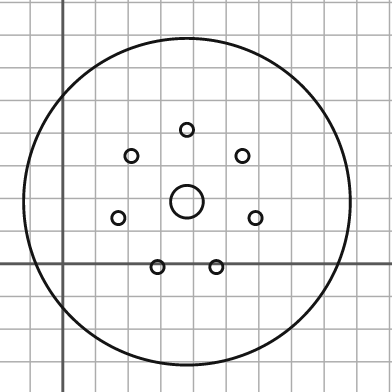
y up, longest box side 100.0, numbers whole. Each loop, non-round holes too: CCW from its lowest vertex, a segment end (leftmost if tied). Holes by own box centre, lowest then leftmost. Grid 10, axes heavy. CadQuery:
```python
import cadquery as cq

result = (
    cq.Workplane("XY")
    .moveTo(38.0, 19.0)
    .circle(50.0)
    .moveTo(29.0, -1.0)
    .circle(2.0)
    .moveTo(47.0, -1.0)
    .circle(2.0)
    .moveTo(17.0, 14.0)
    .circle(2.0)
    .moveTo(59.0, 14.0)
    .circle(2.0)
    .moveTo(38.0, 19.0)
    .circle(5.0)
    .moveTo(21.0, 33.0)
    .circle(2.0)
    .moveTo(55.0, 33.0)
    .circle(2.0)
    .moveTo(38.0, 41.0)
    .circle(2.0)
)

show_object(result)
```